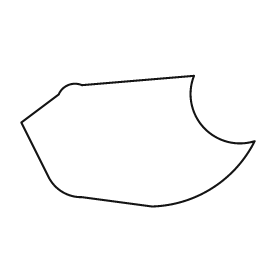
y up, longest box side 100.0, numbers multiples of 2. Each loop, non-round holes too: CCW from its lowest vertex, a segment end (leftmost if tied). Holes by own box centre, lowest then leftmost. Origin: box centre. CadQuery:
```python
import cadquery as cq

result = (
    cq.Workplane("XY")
    .moveTo(6.0, -28.0)
    .threePointArc((32.0, -20.0), (50.0, 0.0))
    .threePointArc((28.0, 6.0), (24.0, 28.0))
    .lineTo(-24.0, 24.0)
    .threePointArc((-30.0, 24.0), (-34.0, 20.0))
    .lineTo(-50.0, 8.0)
    .lineTo(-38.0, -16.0)
    .threePointArc((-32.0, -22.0), (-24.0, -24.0))
    .close()
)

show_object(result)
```